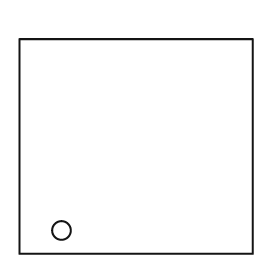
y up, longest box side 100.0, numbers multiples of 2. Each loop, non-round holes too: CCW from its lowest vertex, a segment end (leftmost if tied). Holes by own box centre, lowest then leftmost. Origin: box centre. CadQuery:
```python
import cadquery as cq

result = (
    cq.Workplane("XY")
    .moveTo(-50.0, -46.0)
    .lineTo(50.0, -46.0)
    .lineTo(50.0, 46.0)
    .lineTo(-50.0, 46.0)
    .close()
    .moveTo(-32.0, -36.0)
    .circle(4.0)
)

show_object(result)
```